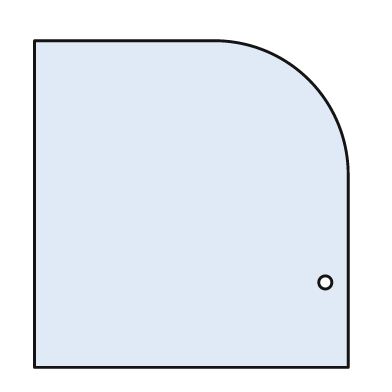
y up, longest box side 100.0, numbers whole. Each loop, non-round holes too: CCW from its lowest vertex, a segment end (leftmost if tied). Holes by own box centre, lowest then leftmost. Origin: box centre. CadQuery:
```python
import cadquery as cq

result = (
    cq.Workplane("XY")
    .moveTo(-48.0, -50.0)
    .lineTo(48.0, -50.0)
    .lineTo(48.0, 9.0)
    .threePointArc((36.0, 38.0), (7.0, 50.0))
    .lineTo(-48.0, 50.0)
    .close()
    .moveTo(41.0, -24.0)
    .circle(2.0)
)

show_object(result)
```